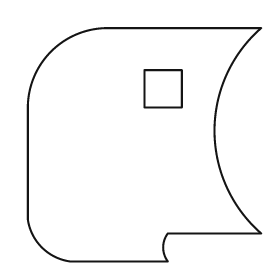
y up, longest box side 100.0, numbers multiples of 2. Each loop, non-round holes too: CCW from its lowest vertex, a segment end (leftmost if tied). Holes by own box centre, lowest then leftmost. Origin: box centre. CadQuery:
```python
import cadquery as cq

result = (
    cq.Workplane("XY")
    .moveTo(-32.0, -50.0)
    .lineTo(10.0, -50.0)
    .threePointArc((8.0, -44.0), (10.0, -38.0))
    .lineTo(50.0, -38.0)
    .threePointArc((30.0, 6.0), (50.0, 50.0))
    .lineTo(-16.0, 50.0)
    .threePointArc((-40.0, 40.0), (-50.0, 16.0))
    .lineTo(-50.0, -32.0)
    .threePointArc((-44.0, -44.0), (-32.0, -50.0))
    .close()
    .moveTo(0.0, 16.0)
    .lineTo(16.0, 16.0)
    .lineTo(16.0, 32.0)
    .lineTo(0.0, 32.0)
    .close()
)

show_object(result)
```